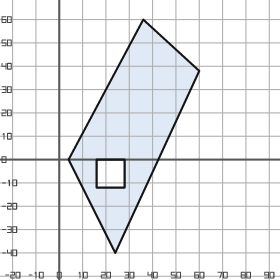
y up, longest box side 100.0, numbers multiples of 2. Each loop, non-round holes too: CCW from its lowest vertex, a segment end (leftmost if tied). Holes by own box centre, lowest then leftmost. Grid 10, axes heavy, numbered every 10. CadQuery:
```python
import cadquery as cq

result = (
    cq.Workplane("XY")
    .moveTo(24.0, -40.0)
    .lineTo(60.0, 38.0)
    .lineTo(36.0, 60.0)
    .lineTo(4.0, 0.0)
    .close()
    .moveTo(16.0, -12.0)
    .lineTo(28.0, -12.0)
    .lineTo(28.0, 0.0)
    .lineTo(16.0, 0.0)
    .close()
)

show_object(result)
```